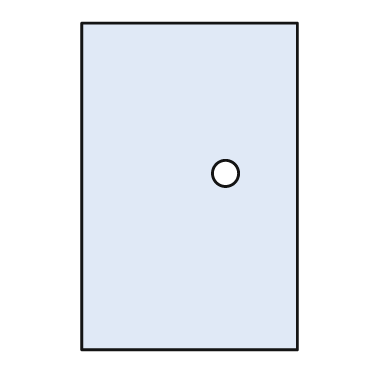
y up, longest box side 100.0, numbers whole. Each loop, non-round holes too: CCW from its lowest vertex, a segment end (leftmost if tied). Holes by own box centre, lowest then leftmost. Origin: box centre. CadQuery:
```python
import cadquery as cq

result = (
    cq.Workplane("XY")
    .moveTo(-33.0, -50.0)
    .lineTo(33.0, -50.0)
    .lineTo(33.0, 50.0)
    .lineTo(-33.0, 50.0)
    .close()
    .moveTo(11.0, 4.0)
    .circle(4.0)
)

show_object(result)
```